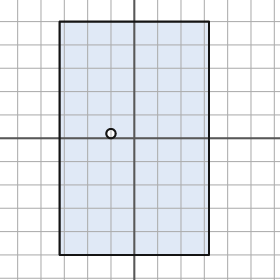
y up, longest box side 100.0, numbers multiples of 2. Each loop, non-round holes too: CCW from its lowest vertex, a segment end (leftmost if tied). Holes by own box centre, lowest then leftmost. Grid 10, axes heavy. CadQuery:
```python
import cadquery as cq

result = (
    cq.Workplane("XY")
    .moveTo(-32.0, -50.0)
    .lineTo(32.0, -50.0)
    .lineTo(32.0, 50.0)
    .lineTo(-32.0, 50.0)
    .close()
    .moveTo(-10.0, 2.0)
    .circle(2.0)
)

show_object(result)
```